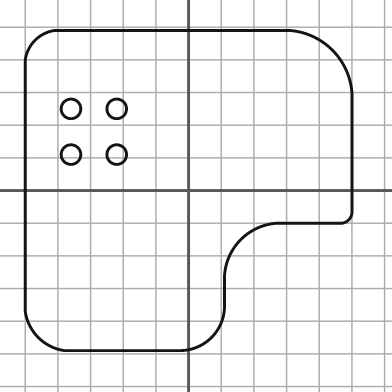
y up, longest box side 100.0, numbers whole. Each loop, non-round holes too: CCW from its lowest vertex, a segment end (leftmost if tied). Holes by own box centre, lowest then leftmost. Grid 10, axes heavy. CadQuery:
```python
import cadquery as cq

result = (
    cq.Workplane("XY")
    .moveTo(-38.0, -49.0)
    .lineTo(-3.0, -49.0)
    .threePointArc((7.0, -45.0), (11.0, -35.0))
    .lineTo(11.0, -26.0)
    .threePointArc((16.0, -15.0), (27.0, -10.0))
    .lineTo(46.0, -10.0)
    .threePointArc((49.0, -9.0), (50.0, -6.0))
    .lineTo(50.0, 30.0)
    .threePointArc((44.0, 43.0), (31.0, 49.0))
    .lineTo(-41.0, 49.0)
    .threePointArc((-47.0, 46.0), (-50.0, 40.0))
    .lineTo(-50.0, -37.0)
    .threePointArc((-46.0, -45.0), (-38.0, -49.0))
    .close()
    .moveTo(-36.0, 11.0)
    .circle(3.0)
    .moveTo(-22.0, 11.0)
    .circle(3.0)
    .moveTo(-36.0, 25.0)
    .circle(3.0)
    .moveTo(-22.0, 25.0)
    .circle(3.0)
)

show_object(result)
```